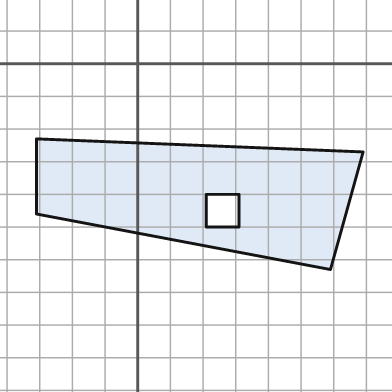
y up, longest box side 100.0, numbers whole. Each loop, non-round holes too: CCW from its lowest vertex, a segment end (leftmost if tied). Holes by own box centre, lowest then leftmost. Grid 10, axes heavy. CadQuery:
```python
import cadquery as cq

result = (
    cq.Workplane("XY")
    .moveTo(59.0, -63.0)
    .lineTo(69.0, -27.0)
    .lineTo(-31.0, -23.0)
    .lineTo(-31.0, -46.0)
    .close()
    .moveTo(21.0, -50.0)
    .lineTo(31.0, -50.0)
    .lineTo(31.0, -40.0)
    .lineTo(21.0, -40.0)
    .close()
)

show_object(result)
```